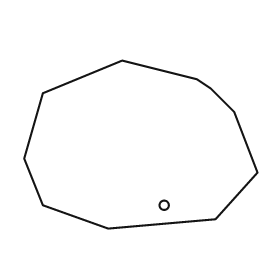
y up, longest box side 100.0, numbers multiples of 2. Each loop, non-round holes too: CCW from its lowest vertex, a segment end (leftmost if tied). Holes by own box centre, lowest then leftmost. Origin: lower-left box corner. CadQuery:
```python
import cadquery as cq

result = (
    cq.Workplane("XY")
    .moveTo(36.0, 0.0)
    .lineTo(82.0, 4.0)
    .lineTo(100.0, 24.0)
    .lineTo(90.0, 50.0)
    .lineTo(80.0, 60.0)
    .lineTo(74.0, 64.0)
    .lineTo(42.0, 72.0)
    .lineTo(8.0, 58.0)
    .lineTo(0.0, 30.0)
    .lineTo(8.0, 10.0)
    .close()
    .moveTo(60.0, 10.0)
    .circle(2.0)
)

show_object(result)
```